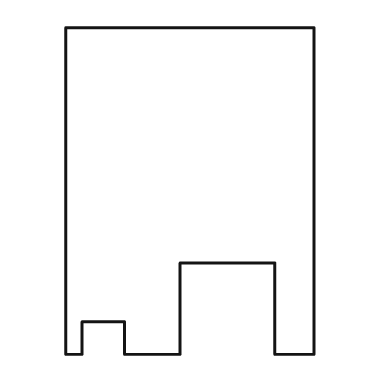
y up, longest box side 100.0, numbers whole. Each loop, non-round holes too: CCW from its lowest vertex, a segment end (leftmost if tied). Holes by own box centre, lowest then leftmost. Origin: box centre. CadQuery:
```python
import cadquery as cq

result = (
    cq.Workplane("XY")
    .moveTo(-38.0, -50.0)
    .lineTo(-33.0, -50.0)
    .lineTo(-33.0, -40.0)
    .lineTo(-20.0, -40.0)
    .lineTo(-20.0, -50.0)
    .lineTo(-3.0, -50.0)
    .lineTo(-3.0, -22.0)
    .lineTo(26.0, -22.0)
    .lineTo(26.0, -50.0)
    .lineTo(38.0, -50.0)
    .lineTo(38.0, 50.0)
    .lineTo(-38.0, 50.0)
    .close()
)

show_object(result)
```